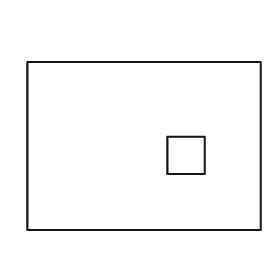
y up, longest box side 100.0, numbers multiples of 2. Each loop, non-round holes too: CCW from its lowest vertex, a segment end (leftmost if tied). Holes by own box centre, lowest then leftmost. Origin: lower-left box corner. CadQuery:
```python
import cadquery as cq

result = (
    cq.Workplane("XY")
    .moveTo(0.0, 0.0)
    .lineTo(100.0, 0.0)
    .lineTo(100.0, 72.0)
    .lineTo(0.0, 72.0)
    .close()
    .moveTo(60.0, 24.0)
    .lineTo(76.0, 24.0)
    .lineTo(76.0, 40.0)
    .lineTo(60.0, 40.0)
    .close()
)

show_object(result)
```